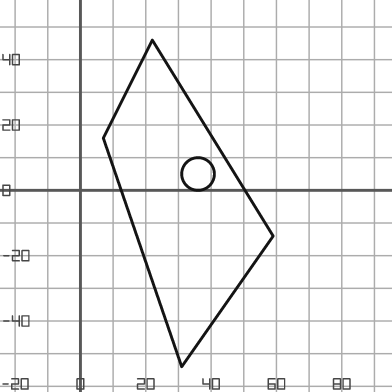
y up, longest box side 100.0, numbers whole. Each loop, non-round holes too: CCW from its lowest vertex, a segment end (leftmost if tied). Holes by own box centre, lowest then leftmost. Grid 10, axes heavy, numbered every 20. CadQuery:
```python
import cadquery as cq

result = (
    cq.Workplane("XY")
    .moveTo(31.0, -54.0)
    .lineTo(59.0, -14.0)
    .lineTo(22.0, 46.0)
    .lineTo(7.0, 16.0)
    .close()
    .moveTo(36.0, 5.0)
    .circle(5.0)
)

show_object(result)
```